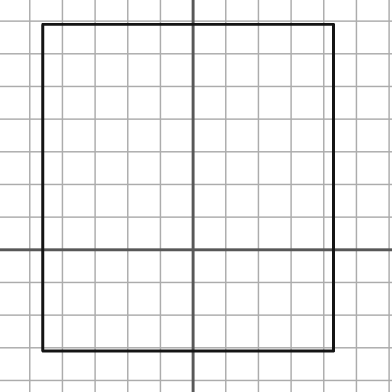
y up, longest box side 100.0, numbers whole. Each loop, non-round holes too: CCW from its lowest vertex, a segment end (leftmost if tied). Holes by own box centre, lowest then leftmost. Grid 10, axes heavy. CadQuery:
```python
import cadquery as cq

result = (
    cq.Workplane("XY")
    .moveTo(-46.0, -31.0)
    .lineTo(43.0, -31.0)
    .lineTo(43.0, 69.0)
    .lineTo(-46.0, 69.0)
    .close()
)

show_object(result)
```